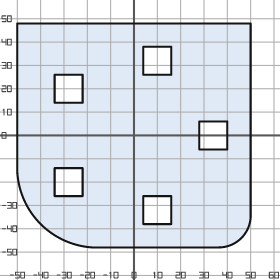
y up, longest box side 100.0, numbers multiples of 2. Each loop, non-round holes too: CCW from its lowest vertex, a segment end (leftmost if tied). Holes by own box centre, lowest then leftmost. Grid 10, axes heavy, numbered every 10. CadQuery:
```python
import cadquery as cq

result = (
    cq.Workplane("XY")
    .moveTo(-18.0, -48.0)
    .lineTo(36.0, -48.0)
    .threePointArc((46.0, -44.0), (50.0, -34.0))
    .lineTo(50.0, 48.0)
    .lineTo(-50.0, 48.0)
    .lineTo(-50.0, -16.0)
    .threePointArc((-40.0, -38.0), (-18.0, -48.0))
    .close()
    .moveTo(4.0, -38.0)
    .lineTo(16.0, -38.0)
    .lineTo(16.0, -26.0)
    .lineTo(4.0, -26.0)
    .close()
    .moveTo(-34.0, -26.0)
    .lineTo(-22.0, -26.0)
    .lineTo(-22.0, -14.0)
    .lineTo(-34.0, -14.0)
    .close()
    .moveTo(28.0, -6.0)
    .lineTo(40.0, -6.0)
    .lineTo(40.0, 6.0)
    .lineTo(28.0, 6.0)
    .close()
    .moveTo(-34.0, 14.0)
    .lineTo(-22.0, 14.0)
    .lineTo(-22.0, 26.0)
    .lineTo(-34.0, 26.0)
    .close()
    .moveTo(4.0, 26.0)
    .lineTo(16.0, 26.0)
    .lineTo(16.0, 38.0)
    .lineTo(4.0, 38.0)
    .close()
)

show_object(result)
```